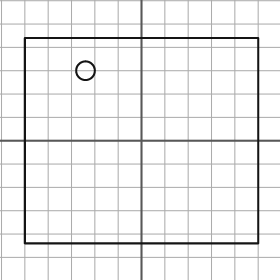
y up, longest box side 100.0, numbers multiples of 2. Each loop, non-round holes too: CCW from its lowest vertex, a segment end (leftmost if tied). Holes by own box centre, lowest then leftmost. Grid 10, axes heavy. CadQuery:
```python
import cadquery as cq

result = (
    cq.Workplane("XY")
    .moveTo(-50.0, -44.0)
    .lineTo(50.0, -44.0)
    .lineTo(50.0, 44.0)
    .lineTo(-50.0, 44.0)
    .close()
    .moveTo(-24.0, 30.0)
    .circle(4.0)
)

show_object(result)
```